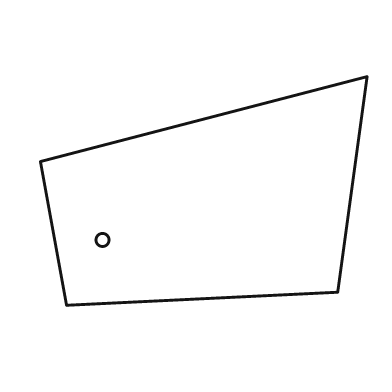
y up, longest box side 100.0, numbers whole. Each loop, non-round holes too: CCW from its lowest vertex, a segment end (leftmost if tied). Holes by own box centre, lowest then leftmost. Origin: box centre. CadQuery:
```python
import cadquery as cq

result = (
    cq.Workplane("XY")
    .moveTo(-42.0, -35.0)
    .lineTo(41.0, -31.0)
    .lineTo(50.0, 35.0)
    .lineTo(-50.0, 9.0)
    .close()
    .moveTo(-31.0, -15.0)
    .circle(2.0)
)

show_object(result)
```